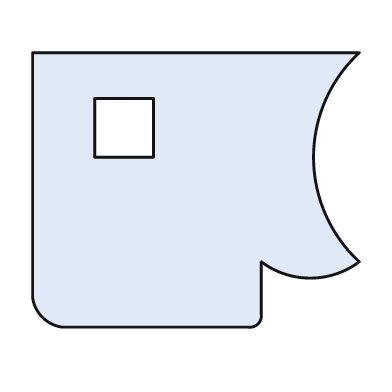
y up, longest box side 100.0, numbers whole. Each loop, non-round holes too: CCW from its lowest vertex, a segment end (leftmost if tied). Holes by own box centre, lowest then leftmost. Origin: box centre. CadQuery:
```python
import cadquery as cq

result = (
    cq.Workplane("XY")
    .moveTo(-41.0, -42.0)
    .lineTo(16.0, -42.0)
    .threePointArc((19.0, -41.0), (20.0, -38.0))
    .lineTo(20.0, -22.0)
    .threePointArc((35.0, -27.0), (50.0, -22.0))
    .threePointArc((36.0, 10.0), (50.0, 42.0))
    .lineTo(-50.0, 42.0)
    .lineTo(-50.0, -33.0)
    .threePointArc((-47.0, -39.0), (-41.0, -42.0))
    .close()
    .moveTo(-31.0, 10.0)
    .lineTo(-13.0, 10.0)
    .lineTo(-13.0, 28.0)
    .lineTo(-31.0, 28.0)
    .close()
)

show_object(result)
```